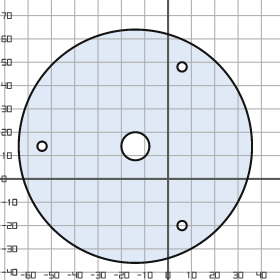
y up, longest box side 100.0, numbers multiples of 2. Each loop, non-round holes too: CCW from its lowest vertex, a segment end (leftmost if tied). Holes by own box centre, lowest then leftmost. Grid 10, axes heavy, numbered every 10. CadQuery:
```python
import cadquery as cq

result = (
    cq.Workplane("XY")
    .moveTo(-14.0, 14.0)
    .circle(50.0)
    .moveTo(6.0, -20.0)
    .circle(2.0)
    .moveTo(-54.0, 14.0)
    .circle(2.0)
    .moveTo(-14.0, 14.0)
    .circle(6.0)
    .moveTo(6.0, 48.0)
    .circle(2.0)
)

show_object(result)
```